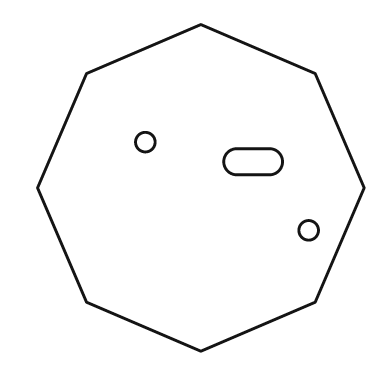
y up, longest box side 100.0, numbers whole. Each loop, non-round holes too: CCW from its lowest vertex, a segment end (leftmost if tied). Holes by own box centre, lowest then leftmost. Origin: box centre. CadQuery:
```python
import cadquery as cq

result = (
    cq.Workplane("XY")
    .moveTo(0.0, -50.0)
    .lineTo(35.0, -35.0)
    .lineTo(50.0, 0.0)
    .lineTo(35.0, 35.0)
    .lineTo(0.0, 50.0)
    .lineTo(-35.0, 35.0)
    .lineTo(-50.0, 0.0)
    .lineTo(-35.0, -35.0)
    .close()
    .moveTo(33.0, -13.0)
    .circle(3.0)
    .moveTo(11.0, 4.0)
    .lineTo(21.0, 4.0)
    .threePointArc((25.0, 8.0), (21.0, 12.0))
    .lineTo(11.0, 12.0)
    .threePointArc((7.0, 8.0), (11.0, 4.0))
    .close()
    .moveTo(-17.0, 14.0)
    .circle(3.0)
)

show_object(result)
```